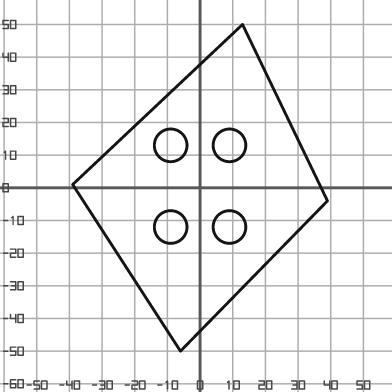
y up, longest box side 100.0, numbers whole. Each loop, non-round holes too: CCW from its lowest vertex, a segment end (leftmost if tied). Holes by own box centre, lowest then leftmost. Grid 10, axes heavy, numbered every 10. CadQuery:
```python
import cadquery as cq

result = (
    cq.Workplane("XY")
    .moveTo(-6.0, -50.0)
    .lineTo(39.0, -4.0)
    .lineTo(13.0, 50.0)
    .lineTo(-39.0, 1.0)
    .close()
    .moveTo(-9.0, -12.0)
    .circle(5.0)
    .moveTo(9.0, -12.0)
    .circle(5.0)
    .moveTo(-9.0, 13.0)
    .circle(5.0)
    .moveTo(9.0, 13.0)
    .circle(5.0)
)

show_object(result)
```